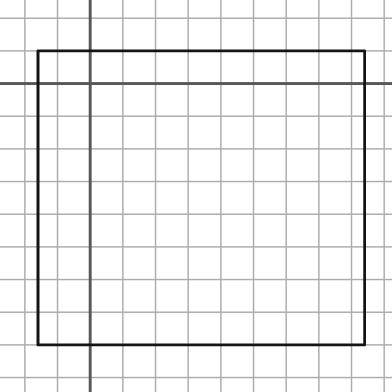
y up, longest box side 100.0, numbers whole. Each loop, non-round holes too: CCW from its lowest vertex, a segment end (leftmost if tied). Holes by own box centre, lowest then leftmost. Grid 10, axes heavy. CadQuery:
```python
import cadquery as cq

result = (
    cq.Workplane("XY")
    .moveTo(-16.0, -80.0)
    .lineTo(84.0, -80.0)
    .lineTo(84.0, 10.0)
    .lineTo(-16.0, 10.0)
    .close()
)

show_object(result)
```